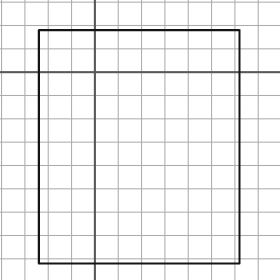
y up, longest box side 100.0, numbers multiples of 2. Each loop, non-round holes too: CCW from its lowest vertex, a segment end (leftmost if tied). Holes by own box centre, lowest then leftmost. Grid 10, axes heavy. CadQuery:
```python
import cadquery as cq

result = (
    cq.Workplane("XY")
    .moveTo(-24.0, -82.0)
    .lineTo(62.0, -82.0)
    .lineTo(62.0, 18.0)
    .lineTo(-24.0, 18.0)
    .close()
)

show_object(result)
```